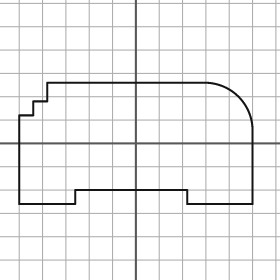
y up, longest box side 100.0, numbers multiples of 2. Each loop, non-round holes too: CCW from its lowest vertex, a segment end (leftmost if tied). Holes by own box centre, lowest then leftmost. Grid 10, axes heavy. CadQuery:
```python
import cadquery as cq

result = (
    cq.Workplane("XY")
    .moveTo(-50.0, -26.0)
    .lineTo(-26.0, -26.0)
    .lineTo(-26.0, -20.0)
    .lineTo(22.0, -20.0)
    .lineTo(22.0, -26.0)
    .lineTo(50.0, -26.0)
    .lineTo(50.0, 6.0)
    .threePointArc((44.0, 20.0), (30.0, 26.0))
    .lineTo(-38.0, 26.0)
    .lineTo(-38.0, 18.0)
    .lineTo(-44.0, 18.0)
    .lineTo(-44.0, 12.0)
    .lineTo(-50.0, 12.0)
    .close()
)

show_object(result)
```